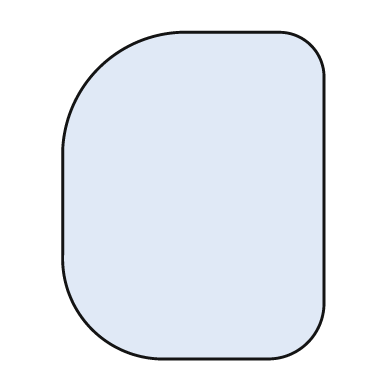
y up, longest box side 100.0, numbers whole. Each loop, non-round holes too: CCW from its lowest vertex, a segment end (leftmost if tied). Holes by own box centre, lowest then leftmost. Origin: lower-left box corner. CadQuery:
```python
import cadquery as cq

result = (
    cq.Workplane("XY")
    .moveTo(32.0, 0.0)
    .lineTo(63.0, 0.0)
    .threePointArc((75.0, 5.0), (80.0, 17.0))
    .lineTo(80.0, 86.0)
    .threePointArc((76.0, 96.0), (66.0, 100.0))
    .lineTo(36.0, 100.0)
    .threePointArc((11.0, 89.0), (0.0, 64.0))
    .lineTo(0.0, 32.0)
    .threePointArc((9.0, 9.0), (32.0, 0.0))
    .close()
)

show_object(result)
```